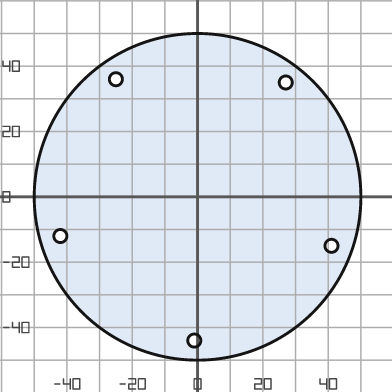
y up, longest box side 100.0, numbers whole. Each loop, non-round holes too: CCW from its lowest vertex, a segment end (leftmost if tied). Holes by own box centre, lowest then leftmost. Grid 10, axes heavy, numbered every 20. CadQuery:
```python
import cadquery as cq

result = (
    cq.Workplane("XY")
    .moveTo(0.0, 0.0)
    .circle(50.0)
    .moveTo(-1.0, -44.0)
    .circle(2.0)
    .moveTo(41.0, -15.0)
    .circle(2.0)
    .moveTo(-42.0, -12.0)
    .circle(2.0)
    .moveTo(27.0, 35.0)
    .circle(2.0)
    .moveTo(-25.0, 36.0)
    .circle(2.0)
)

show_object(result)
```